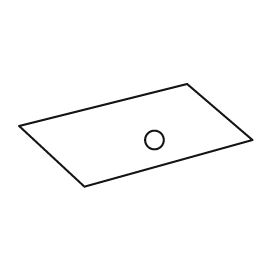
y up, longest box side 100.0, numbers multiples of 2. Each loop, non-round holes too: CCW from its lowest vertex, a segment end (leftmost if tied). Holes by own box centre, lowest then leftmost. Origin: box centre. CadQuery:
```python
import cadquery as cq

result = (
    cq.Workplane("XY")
    .moveTo(-22.0, -22.0)
    .lineTo(50.0, -2.0)
    .lineTo(22.0, 22.0)
    .lineTo(-50.0, 4.0)
    .close()
    .moveTo(8.0, -2.0)
    .circle(4.0)
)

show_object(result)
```